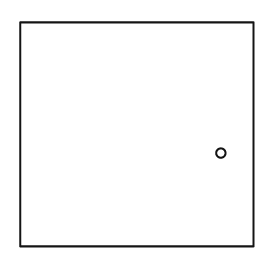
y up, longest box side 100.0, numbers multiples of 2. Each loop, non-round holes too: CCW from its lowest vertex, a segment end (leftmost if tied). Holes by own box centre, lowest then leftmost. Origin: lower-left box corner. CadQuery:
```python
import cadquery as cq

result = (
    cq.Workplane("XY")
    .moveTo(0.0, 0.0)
    .lineTo(100.0, 0.0)
    .lineTo(100.0, 96.0)
    .lineTo(0.0, 96.0)
    .close()
    .moveTo(86.0, 40.0)
    .circle(2.0)
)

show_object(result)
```